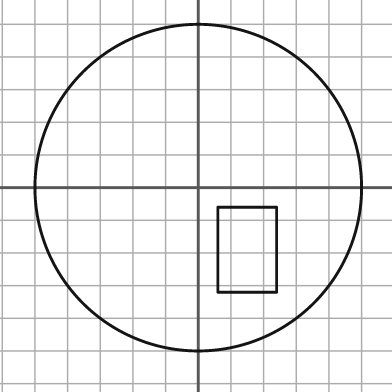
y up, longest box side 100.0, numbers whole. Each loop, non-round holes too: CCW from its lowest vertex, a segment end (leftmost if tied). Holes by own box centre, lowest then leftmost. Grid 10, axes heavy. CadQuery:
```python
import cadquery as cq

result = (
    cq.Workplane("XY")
    .moveTo(0.0, 0.0)
    .circle(50.0)
    .moveTo(6.0, -32.0)
    .lineTo(24.0, -32.0)
    .lineTo(24.0, -6.0)
    .lineTo(6.0, -6.0)
    .close()
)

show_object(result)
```